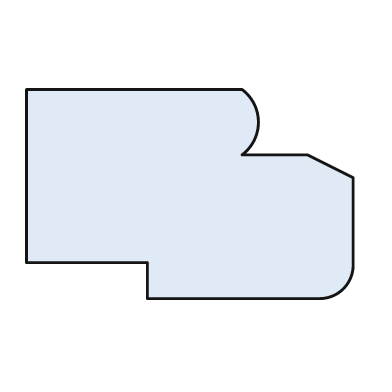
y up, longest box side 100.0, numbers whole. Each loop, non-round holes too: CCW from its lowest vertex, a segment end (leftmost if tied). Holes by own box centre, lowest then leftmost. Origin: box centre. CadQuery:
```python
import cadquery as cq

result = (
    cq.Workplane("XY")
    .moveTo(-13.0, -32.0)
    .lineTo(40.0, -32.0)
    .threePointArc((47.0, -29.0), (50.0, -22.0))
    .lineTo(50.0, 5.0)
    .lineTo(36.0, 12.0)
    .lineTo(16.0, 12.0)
    .threePointArc((21.0, 22.0), (16.0, 32.0))
    .lineTo(-50.0, 32.0)
    .lineTo(-50.0, -21.0)
    .lineTo(-13.0, -21.0)
    .close()
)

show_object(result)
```